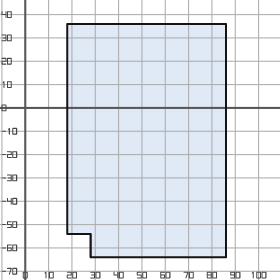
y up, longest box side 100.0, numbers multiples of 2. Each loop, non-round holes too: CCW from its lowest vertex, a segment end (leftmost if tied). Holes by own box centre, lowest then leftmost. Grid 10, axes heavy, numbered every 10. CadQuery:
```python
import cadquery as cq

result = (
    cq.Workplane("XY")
    .moveTo(28.0, -64.0)
    .lineTo(86.0, -64.0)
    .lineTo(86.0, 36.0)
    .lineTo(18.0, 36.0)
    .lineTo(18.0, -54.0)
    .lineTo(28.0, -54.0)
    .close()
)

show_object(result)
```